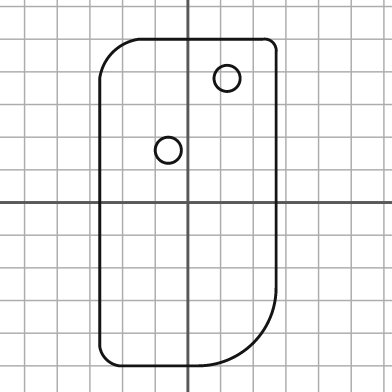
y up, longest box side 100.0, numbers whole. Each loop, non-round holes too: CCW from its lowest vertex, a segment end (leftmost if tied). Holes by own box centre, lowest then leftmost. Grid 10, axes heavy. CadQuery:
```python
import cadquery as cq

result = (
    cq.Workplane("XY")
    .moveTo(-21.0, -50.0)
    .lineTo(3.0, -50.0)
    .threePointArc((20.0, -43.0), (27.0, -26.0))
    .lineTo(27.0, 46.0)
    .threePointArc((26.0, 49.0), (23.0, 50.0))
    .lineTo(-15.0, 50.0)
    .threePointArc((-23.0, 46.0), (-27.0, 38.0))
    .lineTo(-27.0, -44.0)
    .threePointArc((-25.0, -48.0), (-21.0, -50.0))
    .close()
    .moveTo(-6.0, 16.0)
    .circle(4.0)
    .moveTo(12.0, 38.0)
    .circle(4.0)
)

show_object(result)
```